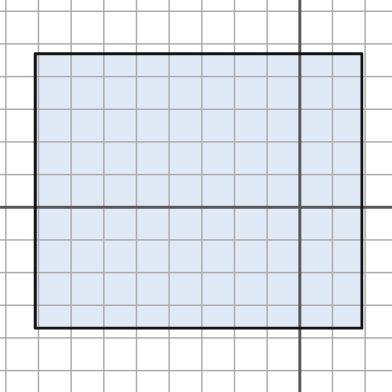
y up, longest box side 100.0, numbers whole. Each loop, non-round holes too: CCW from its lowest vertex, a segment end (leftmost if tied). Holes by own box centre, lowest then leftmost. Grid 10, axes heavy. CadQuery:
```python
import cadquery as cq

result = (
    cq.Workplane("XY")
    .moveTo(-81.0, -37.0)
    .lineTo(19.0, -37.0)
    .lineTo(19.0, 47.0)
    .lineTo(-81.0, 47.0)
    .close()
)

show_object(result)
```